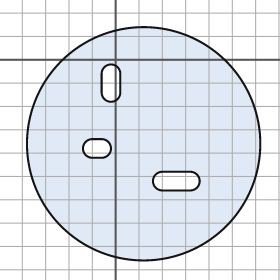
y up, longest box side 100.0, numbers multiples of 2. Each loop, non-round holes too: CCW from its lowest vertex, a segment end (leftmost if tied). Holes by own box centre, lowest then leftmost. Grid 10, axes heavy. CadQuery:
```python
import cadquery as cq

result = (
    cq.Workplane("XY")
    .moveTo(12.0, -36.0)
    .circle(50.0)
    .moveTo(20.0, -56.0)
    .lineTo(32.0, -56.0)
    .threePointArc((36.0, -52.0), (32.0, -48.0))
    .lineTo(20.0, -48.0)
    .threePointArc((16.0, -52.0), (20.0, -56.0))
    .close()
    .moveTo(-10.0, -42.0)
    .lineTo(-6.0, -42.0)
    .threePointArc((-2.0, -38.0), (-6.0, -34.0))
    .lineTo(-10.0, -34.0)
    .threePointArc((-14.0, -38.0), (-10.0, -42.0))
    .close()
    .moveTo(-6.0, -14.0)
    .threePointArc((-2.0, -18.0), (2.0, -14.0))
    .lineTo(2.0, -6.0)
    .threePointArc((-2.0, -2.0), (-6.0, -6.0))
    .close()
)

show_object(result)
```